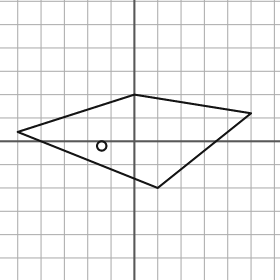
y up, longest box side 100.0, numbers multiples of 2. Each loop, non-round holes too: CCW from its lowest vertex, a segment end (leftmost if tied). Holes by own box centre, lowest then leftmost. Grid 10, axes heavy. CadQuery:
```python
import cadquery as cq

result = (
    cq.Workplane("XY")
    .moveTo(10.0, -20.0)
    .lineTo(50.0, 12.0)
    .lineTo(0.0, 20.0)
    .lineTo(-50.0, 4.0)
    .close()
    .moveTo(-14.0, -2.0)
    .circle(2.0)
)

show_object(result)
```